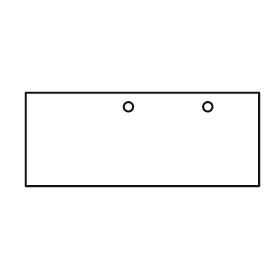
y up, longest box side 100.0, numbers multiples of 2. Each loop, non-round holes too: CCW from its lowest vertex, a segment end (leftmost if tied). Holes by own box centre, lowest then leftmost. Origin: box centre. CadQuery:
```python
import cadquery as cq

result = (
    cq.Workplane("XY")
    .moveTo(-50.0, -20.0)
    .lineTo(50.0, -20.0)
    .lineTo(50.0, 20.0)
    .lineTo(-50.0, 20.0)
    .close()
    .moveTo(-6.0, 14.0)
    .circle(2.0)
    .moveTo(28.0, 14.0)
    .circle(2.0)
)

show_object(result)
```